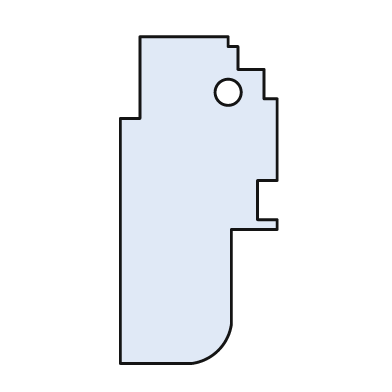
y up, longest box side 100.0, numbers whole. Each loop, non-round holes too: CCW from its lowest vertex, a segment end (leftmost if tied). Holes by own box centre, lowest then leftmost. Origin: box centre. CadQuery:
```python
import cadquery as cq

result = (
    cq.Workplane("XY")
    .moveTo(-24.0, -50.0)
    .lineTo(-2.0, -50.0)
    .threePointArc((6.0, -46.0), (10.0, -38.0))
    .lineTo(10.0, -9.0)
    .lineTo(24.0, -9.0)
    .lineTo(24.0, -6.0)
    .lineTo(18.0, -6.0)
    .lineTo(18.0, 6.0)
    .lineTo(24.0, 6.0)
    .lineTo(24.0, 31.0)
    .lineTo(20.0, 31.0)
    .lineTo(20.0, 40.0)
    .lineTo(12.0, 40.0)
    .lineTo(12.0, 47.0)
    .lineTo(9.0, 47.0)
    .lineTo(9.0, 50.0)
    .lineTo(-18.0, 50.0)
    .lineTo(-18.0, 25.0)
    .lineTo(-24.0, 25.0)
    .close()
    .moveTo(9.0, 33.0)
    .circle(4.0)
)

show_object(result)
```